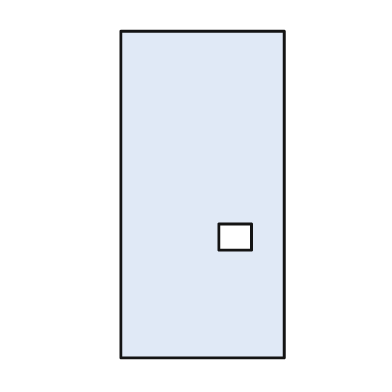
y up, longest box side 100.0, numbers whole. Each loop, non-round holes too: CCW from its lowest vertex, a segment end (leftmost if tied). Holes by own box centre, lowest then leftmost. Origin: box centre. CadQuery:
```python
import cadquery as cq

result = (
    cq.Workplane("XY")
    .moveTo(-25.0, -50.0)
    .lineTo(25.0, -50.0)
    .lineTo(25.0, 50.0)
    .lineTo(-25.0, 50.0)
    .close()
    .moveTo(5.0, -17.0)
    .lineTo(15.0, -17.0)
    .lineTo(15.0, -9.0)
    .lineTo(5.0, -9.0)
    .close()
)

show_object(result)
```